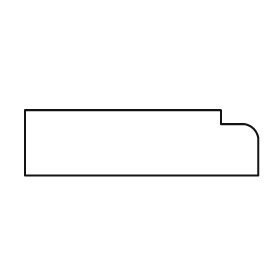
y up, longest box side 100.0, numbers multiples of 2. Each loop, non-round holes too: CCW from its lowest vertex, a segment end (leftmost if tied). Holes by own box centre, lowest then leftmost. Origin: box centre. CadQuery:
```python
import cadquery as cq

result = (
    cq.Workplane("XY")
    .moveTo(-50.0, -14.0)
    .lineTo(50.0, -14.0)
    .lineTo(50.0, 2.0)
    .threePointArc((48.0, 6.0), (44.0, 8.0))
    .lineTo(34.0, 8.0)
    .lineTo(34.0, 14.0)
    .lineTo(-50.0, 14.0)
    .close()
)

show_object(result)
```